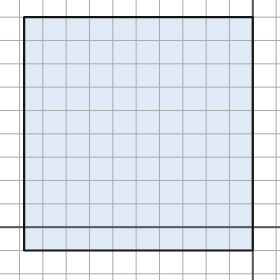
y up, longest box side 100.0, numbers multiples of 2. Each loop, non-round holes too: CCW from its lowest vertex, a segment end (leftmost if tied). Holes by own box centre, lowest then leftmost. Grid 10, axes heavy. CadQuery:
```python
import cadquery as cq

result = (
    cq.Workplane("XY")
    .moveTo(-98.0, -10.0)
    .lineTo(0.0, -10.0)
    .lineTo(0.0, 90.0)
    .lineTo(-98.0, 90.0)
    .close()
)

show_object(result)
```